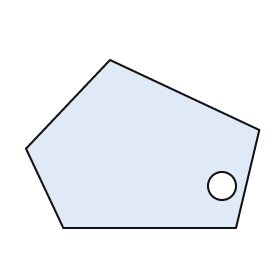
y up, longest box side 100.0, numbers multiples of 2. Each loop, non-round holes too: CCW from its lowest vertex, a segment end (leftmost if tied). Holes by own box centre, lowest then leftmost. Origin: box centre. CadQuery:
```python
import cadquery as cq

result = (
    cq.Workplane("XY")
    .moveTo(-34.0, -36.0)
    .lineTo(40.0, -36.0)
    .lineTo(50.0, 6.0)
    .lineTo(-14.0, 36.0)
    .lineTo(-50.0, -2.0)
    .close()
    .moveTo(34.0, -18.0)
    .circle(6.0)
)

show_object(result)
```